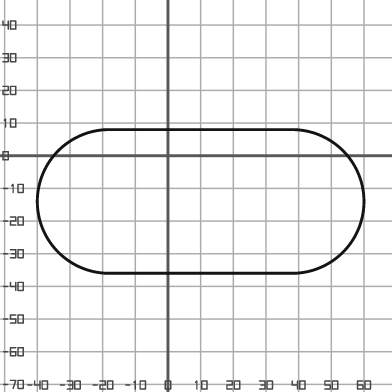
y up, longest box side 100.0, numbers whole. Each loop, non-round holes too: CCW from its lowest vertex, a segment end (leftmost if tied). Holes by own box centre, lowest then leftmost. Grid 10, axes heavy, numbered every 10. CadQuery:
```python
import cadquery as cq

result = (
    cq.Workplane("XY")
    .moveTo(-18.0, -36.0)
    .lineTo(38.0, -36.0)
    .threePointArc((60.0, -14.0), (38.0, 8.0))
    .lineTo(-18.0, 8.0)
    .threePointArc((-40.0, -14.0), (-18.0, -36.0))
    .close()
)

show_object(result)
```